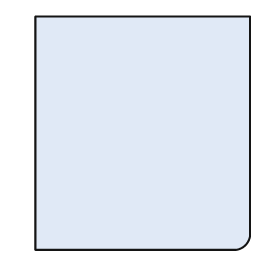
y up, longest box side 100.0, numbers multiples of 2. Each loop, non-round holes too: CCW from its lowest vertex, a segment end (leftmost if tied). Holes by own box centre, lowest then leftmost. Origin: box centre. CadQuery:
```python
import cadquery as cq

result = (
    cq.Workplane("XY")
    .moveTo(-46.0, -50.0)
    .lineTo(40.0, -50.0)
    .threePointArc((44.0, -48.0), (46.0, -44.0))
    .lineTo(46.0, 50.0)
    .lineTo(-46.0, 50.0)
    .close()
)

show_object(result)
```